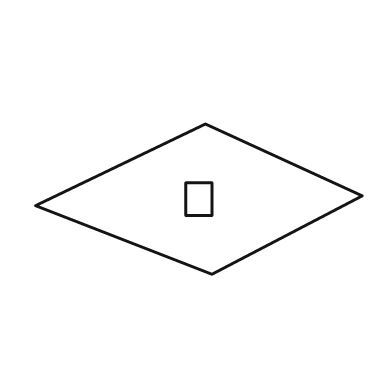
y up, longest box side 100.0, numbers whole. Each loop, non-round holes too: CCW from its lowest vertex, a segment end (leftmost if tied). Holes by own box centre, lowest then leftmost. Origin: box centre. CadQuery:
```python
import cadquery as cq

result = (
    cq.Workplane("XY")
    .moveTo(4.0, -23.0)
    .lineTo(50.0, 1.0)
    .lineTo(2.0, 23.0)
    .lineTo(-50.0, -2.0)
    .close()
    .moveTo(-4.0, -5.0)
    .lineTo(4.0, -5.0)
    .lineTo(4.0, 5.0)
    .lineTo(-4.0, 5.0)
    .close()
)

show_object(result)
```